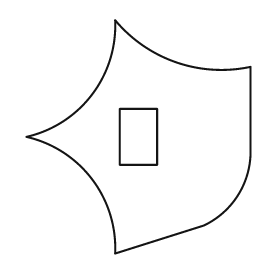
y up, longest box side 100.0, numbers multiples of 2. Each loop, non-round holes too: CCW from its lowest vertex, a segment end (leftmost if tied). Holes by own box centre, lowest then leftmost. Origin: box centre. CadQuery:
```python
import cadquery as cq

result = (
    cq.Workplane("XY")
    .moveTo(-10.0, -50.0)
    .lineTo(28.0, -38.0)
    .threePointArc((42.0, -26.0), (48.0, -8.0))
    .lineTo(48.0, 30.0)
    .threePointArc((16.0, 32.0), (-10.0, 50.0))
    .threePointArc((-20.0, 18.0), (-48.0, 0.0))
    .threePointArc((-20.0, -18.0), (-10.0, -50.0))
    .close()
    .moveTo(-8.0, -12.0)
    .lineTo(8.0, -12.0)
    .lineTo(8.0, 12.0)
    .lineTo(-8.0, 12.0)
    .close()
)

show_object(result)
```